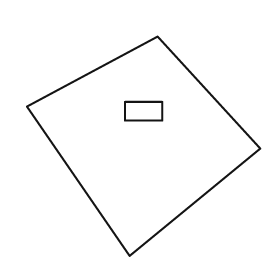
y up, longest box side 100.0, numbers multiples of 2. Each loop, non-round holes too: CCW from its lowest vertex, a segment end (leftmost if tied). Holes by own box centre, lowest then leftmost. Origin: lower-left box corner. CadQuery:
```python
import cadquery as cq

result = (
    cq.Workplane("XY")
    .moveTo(44.0, 0.0)
    .lineTo(100.0, 46.0)
    .lineTo(56.0, 94.0)
    .lineTo(0.0, 64.0)
    .close()
    .moveTo(42.0, 58.0)
    .lineTo(58.0, 58.0)
    .lineTo(58.0, 66.0)
    .lineTo(42.0, 66.0)
    .close()
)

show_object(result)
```